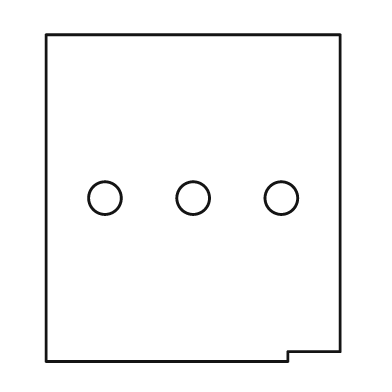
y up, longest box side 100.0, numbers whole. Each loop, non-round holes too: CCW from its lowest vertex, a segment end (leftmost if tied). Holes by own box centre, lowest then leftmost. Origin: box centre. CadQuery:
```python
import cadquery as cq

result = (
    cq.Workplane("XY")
    .moveTo(-45.0, -50.0)
    .lineTo(29.0, -50.0)
    .lineTo(29.0, -47.0)
    .lineTo(45.0, -47.0)
    .lineTo(45.0, 50.0)
    .lineTo(-45.0, 50.0)
    .close()
    .moveTo(-27.0, 0.0)
    .circle(5.0)
    .moveTo(0.0, 0.0)
    .circle(5.0)
    .moveTo(27.0, 0.0)
    .circle(5.0)
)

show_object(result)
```